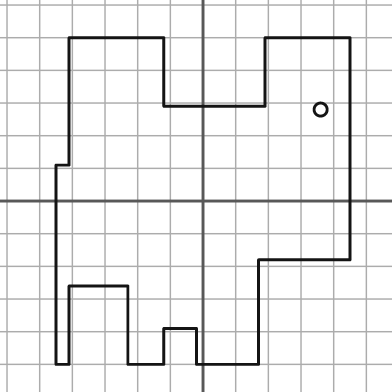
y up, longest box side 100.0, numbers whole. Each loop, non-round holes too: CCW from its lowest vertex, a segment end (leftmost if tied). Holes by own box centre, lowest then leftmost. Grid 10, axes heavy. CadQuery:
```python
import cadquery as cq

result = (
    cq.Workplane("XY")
    .moveTo(-45.0, -50.0)
    .lineTo(-41.0, -50.0)
    .lineTo(-41.0, -26.0)
    .lineTo(-23.0, -26.0)
    .lineTo(-23.0, -50.0)
    .lineTo(-12.0, -50.0)
    .lineTo(-12.0, -39.0)
    .lineTo(-2.0, -39.0)
    .lineTo(-2.0, -50.0)
    .lineTo(17.0, -50.0)
    .lineTo(17.0, -18.0)
    .lineTo(45.0, -18.0)
    .lineTo(45.0, 50.0)
    .lineTo(19.0, 50.0)
    .lineTo(19.0, 29.0)
    .lineTo(-12.0, 29.0)
    .lineTo(-12.0, 50.0)
    .lineTo(-41.0, 50.0)
    .lineTo(-41.0, 11.0)
    .lineTo(-45.0, 11.0)
    .close()
    .moveTo(36.0, 28.0)
    .circle(2.0)
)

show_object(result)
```